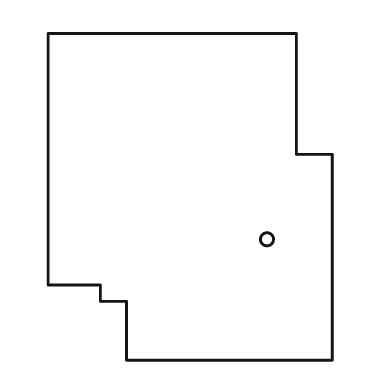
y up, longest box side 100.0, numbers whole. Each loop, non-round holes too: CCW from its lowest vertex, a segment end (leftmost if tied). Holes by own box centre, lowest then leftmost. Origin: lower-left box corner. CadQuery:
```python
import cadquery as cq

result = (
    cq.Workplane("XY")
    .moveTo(24.0, 0.0)
    .lineTo(87.0, 0.0)
    .lineTo(87.0, 63.0)
    .lineTo(76.0, 63.0)
    .lineTo(76.0, 100.0)
    .lineTo(0.0, 100.0)
    .lineTo(0.0, 23.0)
    .lineTo(16.0, 23.0)
    .lineTo(16.0, 18.0)
    .lineTo(24.0, 18.0)
    .close()
    .moveTo(67.0, 37.0)
    .circle(2.0)
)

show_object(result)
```